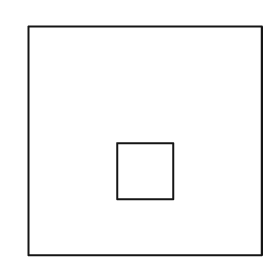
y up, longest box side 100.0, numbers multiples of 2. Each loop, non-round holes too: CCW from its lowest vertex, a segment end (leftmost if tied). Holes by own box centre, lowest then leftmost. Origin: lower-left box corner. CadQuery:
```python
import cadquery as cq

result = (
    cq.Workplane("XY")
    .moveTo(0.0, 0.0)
    .lineTo(100.0, 0.0)
    .lineTo(100.0, 98.0)
    .lineTo(0.0, 98.0)
    .close()
    .moveTo(38.0, 24.0)
    .lineTo(62.0, 24.0)
    .lineTo(62.0, 48.0)
    .lineTo(38.0, 48.0)
    .close()
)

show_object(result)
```